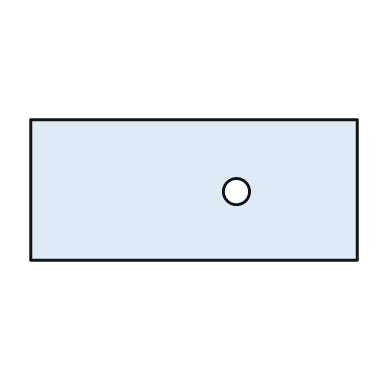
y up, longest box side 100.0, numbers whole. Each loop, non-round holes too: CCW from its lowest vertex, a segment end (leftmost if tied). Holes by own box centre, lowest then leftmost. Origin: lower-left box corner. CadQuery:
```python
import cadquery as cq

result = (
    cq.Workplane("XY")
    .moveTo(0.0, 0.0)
    .lineTo(100.0, 0.0)
    .lineTo(100.0, 43.0)
    .lineTo(0.0, 43.0)
    .close()
    .moveTo(63.0, 21.0)
    .circle(4.0)
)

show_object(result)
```